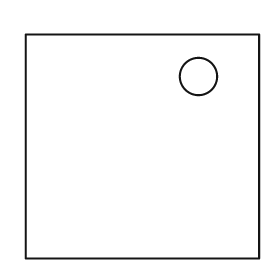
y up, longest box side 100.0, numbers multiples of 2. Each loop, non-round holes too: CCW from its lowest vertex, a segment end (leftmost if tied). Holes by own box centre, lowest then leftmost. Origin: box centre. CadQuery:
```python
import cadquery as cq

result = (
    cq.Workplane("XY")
    .moveTo(-50.0, -48.0)
    .lineTo(50.0, -48.0)
    .lineTo(50.0, 48.0)
    .lineTo(-50.0, 48.0)
    .close()
    .moveTo(24.0, 30.0)
    .circle(8.0)
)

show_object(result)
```